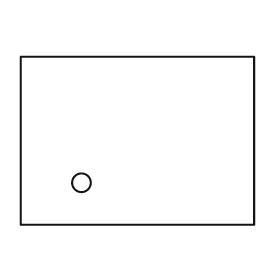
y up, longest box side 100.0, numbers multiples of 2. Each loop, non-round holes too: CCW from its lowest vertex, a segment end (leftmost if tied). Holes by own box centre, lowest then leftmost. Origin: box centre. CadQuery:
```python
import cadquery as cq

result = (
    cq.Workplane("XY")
    .moveTo(-50.0, -36.0)
    .lineTo(50.0, -36.0)
    .lineTo(50.0, 36.0)
    .lineTo(-50.0, 36.0)
    .close()
    .moveTo(-24.0, -18.0)
    .circle(4.0)
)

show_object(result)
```